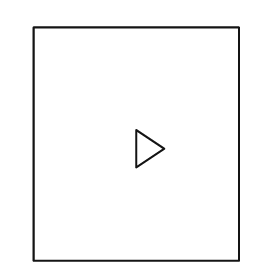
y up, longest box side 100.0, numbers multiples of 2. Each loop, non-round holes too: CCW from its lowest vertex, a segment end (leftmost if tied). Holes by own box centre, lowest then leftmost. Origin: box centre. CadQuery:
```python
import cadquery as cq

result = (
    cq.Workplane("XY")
    .moveTo(-44.0, -50.0)
    .lineTo(44.0, -50.0)
    .lineTo(44.0, 50.0)
    .lineTo(-44.0, 50.0)
    .close()
    .moveTo(0.0, -10.0)
    .lineTo(12.0, -2.0)
    .lineTo(0.0, 6.0)
    .close()
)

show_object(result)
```